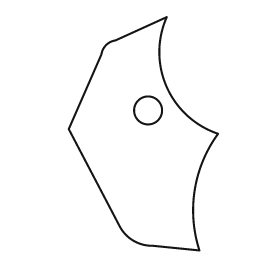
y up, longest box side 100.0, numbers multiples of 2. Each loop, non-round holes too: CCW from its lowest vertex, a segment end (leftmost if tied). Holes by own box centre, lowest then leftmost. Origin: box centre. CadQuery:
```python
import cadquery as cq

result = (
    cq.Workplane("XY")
    .moveTo(24.0, -50.0)
    .threePointArc((22.0, -24.0), (32.0, 0.0))
    .threePointArc((10.0, 20.0), (10.0, 50.0))
    .lineTo(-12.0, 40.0)
    .threePointArc((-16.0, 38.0), (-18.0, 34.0))
    .lineTo(-32.0, 2.0)
    .lineTo(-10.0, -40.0)
    .threePointArc((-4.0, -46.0), (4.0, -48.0))
    .close()
    .moveTo(2.0, 10.0)
    .circle(6.0)
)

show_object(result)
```